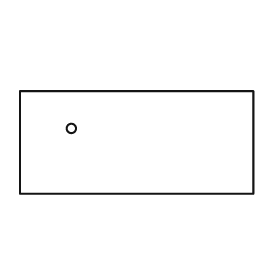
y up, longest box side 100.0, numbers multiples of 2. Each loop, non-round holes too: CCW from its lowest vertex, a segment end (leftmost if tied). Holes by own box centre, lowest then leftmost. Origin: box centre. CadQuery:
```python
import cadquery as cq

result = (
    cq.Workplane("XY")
    .moveTo(-50.0, -22.0)
    .lineTo(50.0, -22.0)
    .lineTo(50.0, 22.0)
    .lineTo(-50.0, 22.0)
    .close()
    .moveTo(-28.0, 6.0)
    .circle(2.0)
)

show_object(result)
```